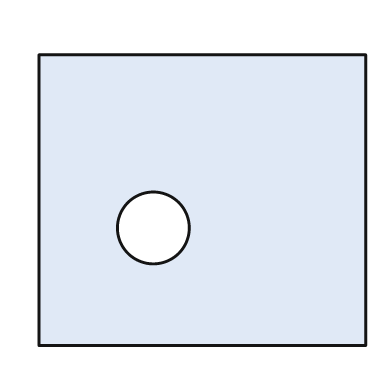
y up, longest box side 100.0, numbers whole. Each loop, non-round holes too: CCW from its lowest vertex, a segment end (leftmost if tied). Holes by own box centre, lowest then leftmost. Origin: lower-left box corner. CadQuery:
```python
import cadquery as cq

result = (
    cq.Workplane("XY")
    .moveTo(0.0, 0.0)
    .lineTo(100.0, 0.0)
    .lineTo(100.0, 89.0)
    .lineTo(0.0, 89.0)
    .close()
    .moveTo(35.0, 36.0)
    .circle(11.0)
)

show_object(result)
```